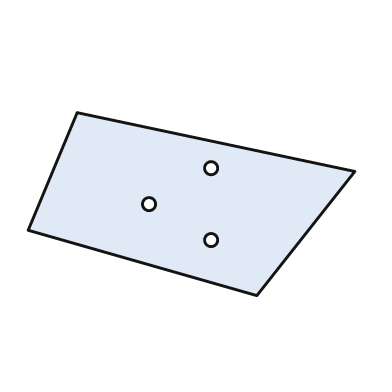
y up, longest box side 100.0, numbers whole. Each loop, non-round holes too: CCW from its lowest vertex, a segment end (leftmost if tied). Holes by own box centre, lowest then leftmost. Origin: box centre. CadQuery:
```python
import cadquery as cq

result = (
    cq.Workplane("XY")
    .moveTo(20.0, -28.0)
    .lineTo(50.0, 10.0)
    .lineTo(-35.0, 28.0)
    .lineTo(-50.0, -8.0)
    .close()
    .moveTo(6.0, -11.0)
    .circle(2.0)
    .moveTo(-13.0, 0.0)
    .circle(2.0)
    .moveTo(6.0, 11.0)
    .circle(2.0)
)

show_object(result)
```